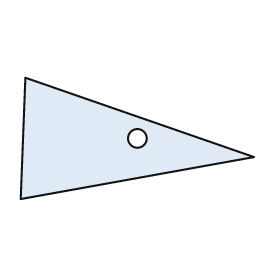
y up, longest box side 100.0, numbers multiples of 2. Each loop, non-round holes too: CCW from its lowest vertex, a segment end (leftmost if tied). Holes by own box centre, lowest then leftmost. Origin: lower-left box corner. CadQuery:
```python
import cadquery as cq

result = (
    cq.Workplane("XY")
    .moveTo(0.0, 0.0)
    .lineTo(100.0, 18.0)
    .lineTo(2.0, 52.0)
    .close()
    .moveTo(50.0, 26.0)
    .circle(4.0)
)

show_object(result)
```